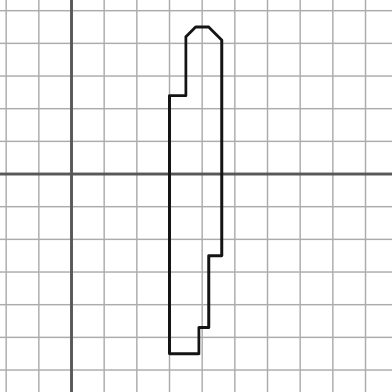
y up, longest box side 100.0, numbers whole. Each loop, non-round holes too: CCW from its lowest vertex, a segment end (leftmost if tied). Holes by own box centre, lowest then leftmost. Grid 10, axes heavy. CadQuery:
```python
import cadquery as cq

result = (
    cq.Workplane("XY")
    .moveTo(30.0, -55.0)
    .lineTo(39.0, -55.0)
    .lineTo(39.0, -47.0)
    .lineTo(42.0, -47.0)
    .lineTo(42.0, -25.0)
    .lineTo(46.0, -25.0)
    .lineTo(46.0, 41.0)
    .lineTo(42.0, 45.0)
    .lineTo(38.0, 45.0)
    .lineTo(35.0, 42.0)
    .lineTo(35.0, 24.0)
    .lineTo(30.0, 24.0)
    .close()
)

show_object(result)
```